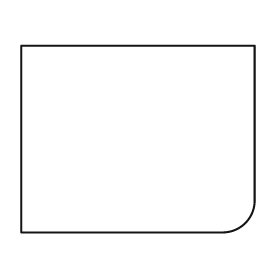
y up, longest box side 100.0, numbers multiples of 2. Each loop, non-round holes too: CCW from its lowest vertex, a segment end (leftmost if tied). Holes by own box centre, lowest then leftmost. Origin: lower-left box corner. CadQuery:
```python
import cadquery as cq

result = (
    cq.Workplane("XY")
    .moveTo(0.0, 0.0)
    .lineTo(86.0, 0.0)
    .threePointArc((96.0, 4.0), (100.0, 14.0))
    .lineTo(100.0, 80.0)
    .lineTo(0.0, 80.0)
    .close()
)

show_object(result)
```